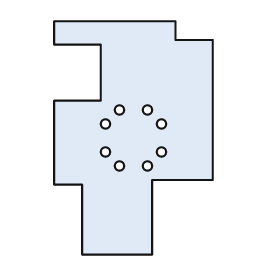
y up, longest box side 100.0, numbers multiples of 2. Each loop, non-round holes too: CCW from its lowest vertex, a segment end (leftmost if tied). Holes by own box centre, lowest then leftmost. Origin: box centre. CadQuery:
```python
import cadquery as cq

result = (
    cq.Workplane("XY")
    .moveTo(-22.0, -50.0)
    .lineTo(8.0, -50.0)
    .lineTo(8.0, -18.0)
    .lineTo(34.0, -18.0)
    .lineTo(34.0, 42.0)
    .lineTo(18.0, 42.0)
    .lineTo(18.0, 50.0)
    .lineTo(-34.0, 50.0)
    .lineTo(-34.0, 40.0)
    .lineTo(-14.0, 40.0)
    .lineTo(-14.0, 16.0)
    .lineTo(-34.0, 16.0)
    .lineTo(-34.0, -20.0)
    .lineTo(-22.0, -20.0)
    .close()
    .moveTo(-6.0, -12.0)
    .circle(2.0)
    .moveTo(6.0, -12.0)
    .circle(2.0)
    .moveTo(-12.0, -6.0)
    .circle(2.0)
    .moveTo(12.0, -6.0)
    .circle(2.0)
    .moveTo(-12.0, 6.0)
    .circle(2.0)
    .moveTo(12.0, 6.0)
    .circle(2.0)
    .moveTo(-6.0, 12.0)
    .circle(2.0)
    .moveTo(6.0, 12.0)
    .circle(2.0)
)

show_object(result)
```